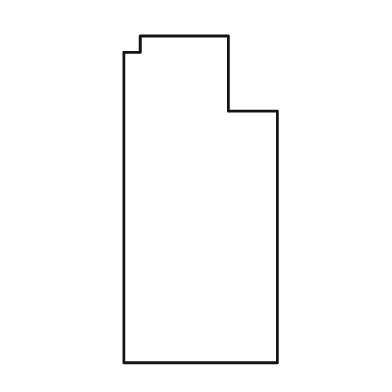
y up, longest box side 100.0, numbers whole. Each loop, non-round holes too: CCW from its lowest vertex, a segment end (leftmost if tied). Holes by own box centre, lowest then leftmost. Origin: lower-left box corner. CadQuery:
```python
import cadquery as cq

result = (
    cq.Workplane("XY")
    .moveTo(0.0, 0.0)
    .lineTo(47.0, 0.0)
    .lineTo(47.0, 77.0)
    .lineTo(32.0, 77.0)
    .lineTo(32.0, 100.0)
    .lineTo(5.0, 100.0)
    .lineTo(5.0, 95.0)
    .lineTo(0.0, 95.0)
    .close()
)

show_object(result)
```